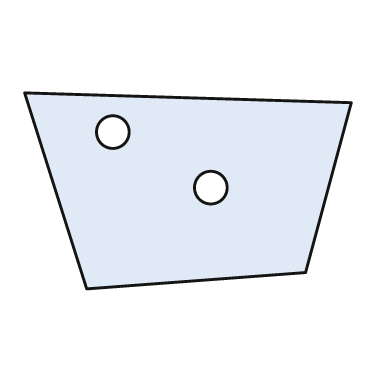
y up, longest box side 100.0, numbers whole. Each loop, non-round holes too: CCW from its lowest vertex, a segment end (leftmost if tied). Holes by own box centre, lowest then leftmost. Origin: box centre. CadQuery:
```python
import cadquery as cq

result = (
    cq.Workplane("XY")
    .moveTo(-31.0, -30.0)
    .lineTo(36.0, -25.0)
    .lineTo(50.0, 27.0)
    .lineTo(-50.0, 30.0)
    .close()
    .moveTo(7.0, 1.0)
    .circle(5.0)
    .moveTo(-23.0, 18.0)
    .circle(5.0)
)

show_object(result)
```